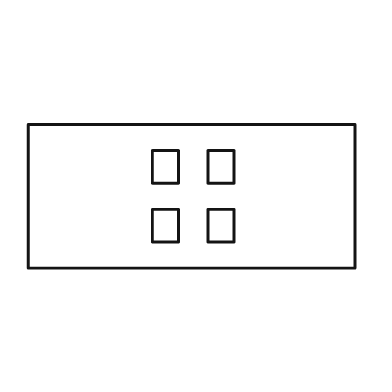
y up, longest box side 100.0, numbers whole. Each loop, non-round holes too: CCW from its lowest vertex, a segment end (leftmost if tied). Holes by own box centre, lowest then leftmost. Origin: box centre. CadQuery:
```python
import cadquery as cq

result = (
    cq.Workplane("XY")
    .moveTo(-50.0, -22.0)
    .lineTo(50.0, -22.0)
    .lineTo(50.0, 22.0)
    .lineTo(-50.0, 22.0)
    .close()
    .moveTo(-12.0, -14.0)
    .lineTo(-4.0, -14.0)
    .lineTo(-4.0, -4.0)
    .lineTo(-12.0, -4.0)
    .close()
    .moveTo(5.0, -14.0)
    .lineTo(13.0, -14.0)
    .lineTo(13.0, -4.0)
    .lineTo(5.0, -4.0)
    .close()
    .moveTo(-12.0, 4.0)
    .lineTo(-4.0, 4.0)
    .lineTo(-4.0, 14.0)
    .lineTo(-12.0, 14.0)
    .close()
    .moveTo(5.0, 4.0)
    .lineTo(13.0, 4.0)
    .lineTo(13.0, 14.0)
    .lineTo(5.0, 14.0)
    .close()
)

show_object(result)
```